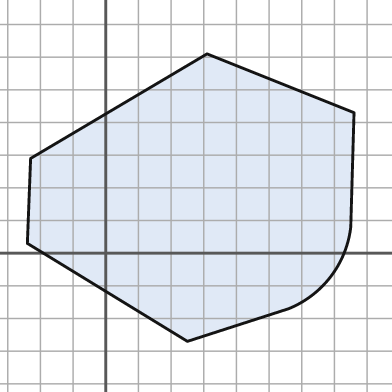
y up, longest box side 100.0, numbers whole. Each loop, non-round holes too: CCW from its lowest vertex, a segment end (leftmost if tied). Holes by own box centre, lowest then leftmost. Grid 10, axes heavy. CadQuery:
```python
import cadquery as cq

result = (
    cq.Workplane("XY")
    .moveTo(25.0, -27.0)
    .lineTo(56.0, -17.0)
    .threePointArc((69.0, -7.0), (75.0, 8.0))
    .lineTo(76.0, 43.0)
    .lineTo(31.0, 61.0)
    .lineTo(-23.0, 29.0)
    .lineTo(-24.0, 3.0)
    .close()
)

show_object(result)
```